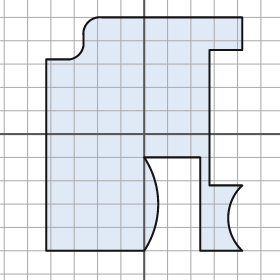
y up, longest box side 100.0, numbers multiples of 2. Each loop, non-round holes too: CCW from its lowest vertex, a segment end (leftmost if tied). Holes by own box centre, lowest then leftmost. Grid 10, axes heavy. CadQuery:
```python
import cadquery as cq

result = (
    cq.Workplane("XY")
    .moveTo(-42.0, -50.0)
    .lineTo(0.0, -50.0)
    .threePointArc((6.0, -30.0), (0.0, -10.0))
    .lineTo(24.0, -10.0)
    .lineTo(24.0, -50.0)
    .lineTo(42.0, -50.0)
    .threePointArc((36.0, -36.0), (42.0, -22.0))
    .lineTo(28.0, -22.0)
    .lineTo(28.0, 36.0)
    .lineTo(42.0, 36.0)
    .lineTo(42.0, 50.0)
    .lineTo(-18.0, 50.0)
    .threePointArc((-24.0, 48.0), (-26.0, 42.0))
    .lineTo(-26.0, 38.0)
    .threePointArc((-28.0, 34.0), (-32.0, 32.0))
    .lineTo(-42.0, 32.0)
    .close()
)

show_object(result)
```